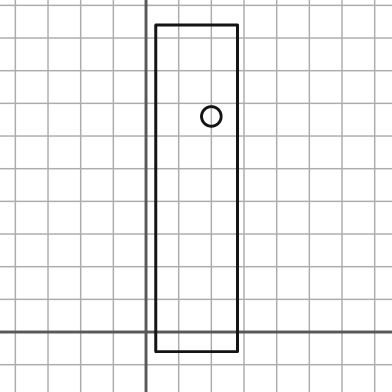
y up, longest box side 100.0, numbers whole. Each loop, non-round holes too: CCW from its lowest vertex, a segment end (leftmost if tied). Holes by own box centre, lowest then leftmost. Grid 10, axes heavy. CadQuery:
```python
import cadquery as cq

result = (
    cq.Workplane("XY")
    .moveTo(3.0, -6.0)
    .lineTo(28.0, -6.0)
    .lineTo(28.0, 94.0)
    .lineTo(3.0, 94.0)
    .close()
    .moveTo(20.0, 66.0)
    .circle(3.0)
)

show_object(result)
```